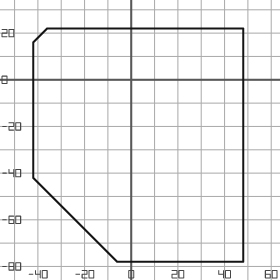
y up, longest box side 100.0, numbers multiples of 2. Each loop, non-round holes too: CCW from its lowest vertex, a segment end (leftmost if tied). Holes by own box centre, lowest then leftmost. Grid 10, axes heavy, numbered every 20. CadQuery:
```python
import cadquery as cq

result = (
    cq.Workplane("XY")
    .moveTo(-6.0, -78.0)
    .lineTo(48.0, -78.0)
    .lineTo(48.0, 22.0)
    .lineTo(-36.0, 22.0)
    .lineTo(-42.0, 16.0)
    .lineTo(-42.0, -42.0)
    .close()
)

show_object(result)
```